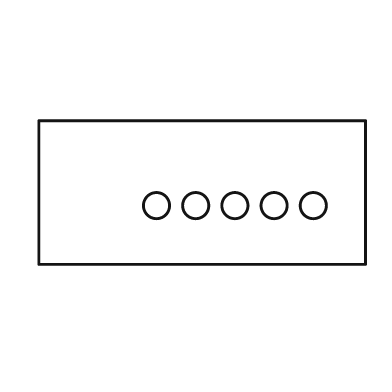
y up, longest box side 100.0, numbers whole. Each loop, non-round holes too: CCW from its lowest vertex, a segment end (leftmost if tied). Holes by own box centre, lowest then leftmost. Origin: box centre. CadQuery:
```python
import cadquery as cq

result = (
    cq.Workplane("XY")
    .moveTo(-50.0, -22.0)
    .lineTo(50.0, -22.0)
    .lineTo(50.0, 22.0)
    .lineTo(-50.0, 22.0)
    .close()
    .moveTo(-14.0, -4.0)
    .circle(4.0)
    .moveTo(-2.0, -4.0)
    .circle(4.0)
    .moveTo(10.0, -4.0)
    .circle(4.0)
    .moveTo(22.0, -4.0)
    .circle(4.0)
    .moveTo(34.0, -4.0)
    .circle(4.0)
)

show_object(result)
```